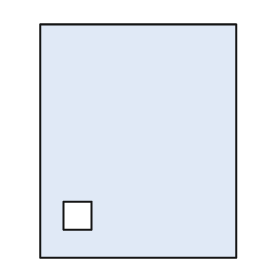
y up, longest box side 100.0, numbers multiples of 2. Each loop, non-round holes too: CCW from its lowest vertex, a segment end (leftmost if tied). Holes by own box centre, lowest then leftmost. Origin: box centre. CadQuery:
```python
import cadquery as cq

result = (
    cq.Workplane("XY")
    .moveTo(-42.0, -50.0)
    .lineTo(42.0, -50.0)
    .lineTo(42.0, 50.0)
    .lineTo(-42.0, 50.0)
    .close()
    .moveTo(-32.0, -38.0)
    .lineTo(-20.0, -38.0)
    .lineTo(-20.0, -26.0)
    .lineTo(-32.0, -26.0)
    .close()
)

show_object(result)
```